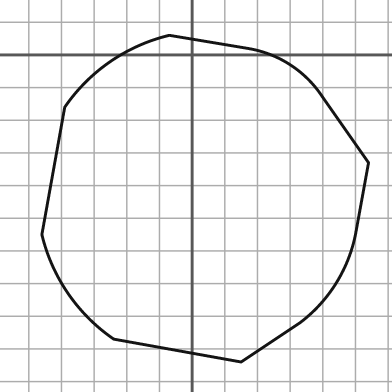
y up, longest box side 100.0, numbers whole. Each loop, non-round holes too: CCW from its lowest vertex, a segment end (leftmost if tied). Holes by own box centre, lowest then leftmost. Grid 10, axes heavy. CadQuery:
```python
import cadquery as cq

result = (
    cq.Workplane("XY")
    .moveTo(15.0, -94.0)
    .lineTo(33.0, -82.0)
    .threePointArc((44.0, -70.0), (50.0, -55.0))
    .lineTo(54.0, -33.0)
    .lineTo(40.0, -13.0)
    .threePointArc((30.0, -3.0), (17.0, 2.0))
    .lineTo(-7.0, 6.0)
    .threePointArc((-25.0, -2.0), (-39.0, -16.0))
    .lineTo(-46.0, -55.0)
    .threePointArc((-38.0, -73.0), (-24.0, -87.0))
    .close()
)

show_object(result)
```